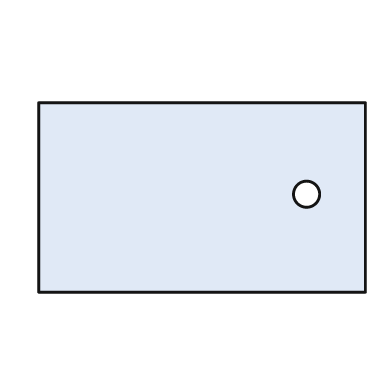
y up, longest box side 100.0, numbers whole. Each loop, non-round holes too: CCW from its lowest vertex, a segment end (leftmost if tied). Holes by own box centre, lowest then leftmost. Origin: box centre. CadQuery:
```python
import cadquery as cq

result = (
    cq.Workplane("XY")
    .moveTo(-50.0, -29.0)
    .lineTo(50.0, -29.0)
    .lineTo(50.0, 29.0)
    .lineTo(-50.0, 29.0)
    .close()
    .moveTo(32.0, 1.0)
    .circle(4.0)
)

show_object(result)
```